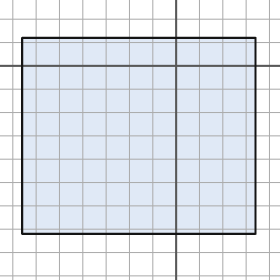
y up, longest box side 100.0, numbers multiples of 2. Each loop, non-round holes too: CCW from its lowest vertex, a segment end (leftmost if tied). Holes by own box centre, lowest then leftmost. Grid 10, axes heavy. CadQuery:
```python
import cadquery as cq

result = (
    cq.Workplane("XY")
    .moveTo(-66.0, -72.0)
    .lineTo(34.0, -72.0)
    .lineTo(34.0, 12.0)
    .lineTo(-66.0, 12.0)
    .close()
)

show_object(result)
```